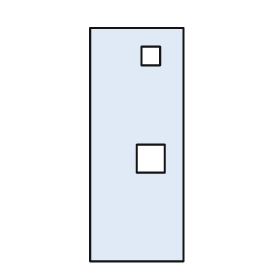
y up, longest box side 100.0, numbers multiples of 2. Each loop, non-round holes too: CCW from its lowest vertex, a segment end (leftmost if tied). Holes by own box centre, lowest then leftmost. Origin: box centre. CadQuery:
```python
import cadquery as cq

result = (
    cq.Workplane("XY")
    .moveTo(-20.0, -50.0)
    .lineTo(20.0, -50.0)
    .lineTo(20.0, 50.0)
    .lineTo(-20.0, 50.0)
    .close()
    .moveTo(0.0, -12.0)
    .lineTo(12.0, -12.0)
    .lineTo(12.0, 0.0)
    .lineTo(0.0, 0.0)
    .close()
    .moveTo(2.0, 34.0)
    .lineTo(10.0, 34.0)
    .lineTo(10.0, 42.0)
    .lineTo(2.0, 42.0)
    .close()
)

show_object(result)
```